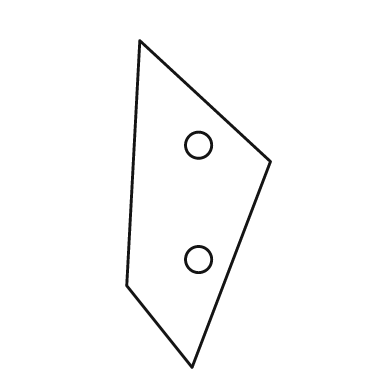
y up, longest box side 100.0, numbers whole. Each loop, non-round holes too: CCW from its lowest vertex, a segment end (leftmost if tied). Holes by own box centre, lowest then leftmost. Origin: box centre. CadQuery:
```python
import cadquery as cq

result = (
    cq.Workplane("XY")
    .moveTo(-2.0, -50.0)
    .lineTo(22.0, 13.0)
    .lineTo(-18.0, 50.0)
    .lineTo(-22.0, -25.0)
    .close()
    .moveTo(0.0, -17.0)
    .circle(4.0)
    .moveTo(0.0, 18.0)
    .circle(4.0)
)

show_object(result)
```